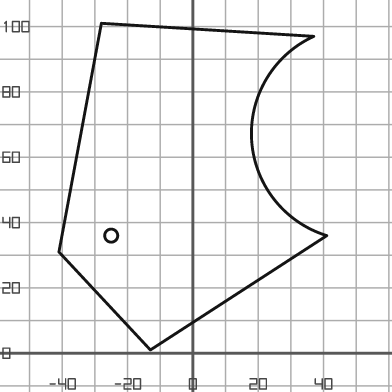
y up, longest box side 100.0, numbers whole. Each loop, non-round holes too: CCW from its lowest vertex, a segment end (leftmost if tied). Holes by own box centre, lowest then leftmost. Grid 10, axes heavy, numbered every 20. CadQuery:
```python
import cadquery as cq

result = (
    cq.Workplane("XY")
    .moveTo(-13.0, 1.0)
    .lineTo(41.0, 36.0)
    .threePointArc((18.0, 65.0), (37.0, 97.0))
    .lineTo(-28.0, 101.0)
    .lineTo(-41.0, 31.0)
    .close()
    .moveTo(-25.0, 36.0)
    .circle(2.0)
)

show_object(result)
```